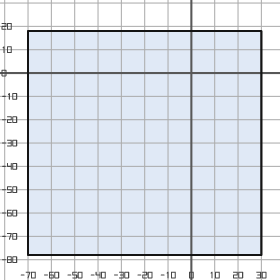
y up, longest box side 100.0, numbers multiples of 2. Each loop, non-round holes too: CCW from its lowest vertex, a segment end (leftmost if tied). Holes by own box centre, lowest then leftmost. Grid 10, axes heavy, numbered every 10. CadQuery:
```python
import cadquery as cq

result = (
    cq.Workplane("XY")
    .moveTo(-70.0, -78.0)
    .lineTo(30.0, -78.0)
    .lineTo(30.0, 18.0)
    .lineTo(-70.0, 18.0)
    .close()
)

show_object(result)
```